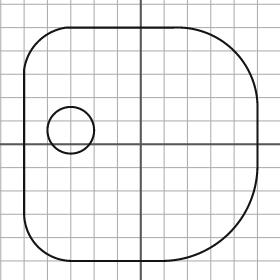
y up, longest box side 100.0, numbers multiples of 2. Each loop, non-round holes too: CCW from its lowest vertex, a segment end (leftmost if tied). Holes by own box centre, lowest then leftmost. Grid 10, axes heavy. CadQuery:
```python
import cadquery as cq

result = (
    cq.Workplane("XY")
    .moveTo(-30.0, -50.0)
    .lineTo(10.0, -50.0)
    .threePointArc((38.0, -38.0), (50.0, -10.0))
    .lineTo(50.0, 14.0)
    .threePointArc((40.0, 40.0), (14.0, 50.0))
    .lineTo(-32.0, 50.0)
    .threePointArc((-44.0, 44.0), (-50.0, 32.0))
    .lineTo(-50.0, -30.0)
    .threePointArc((-44.0, -44.0), (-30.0, -50.0))
    .close()
    .moveTo(-30.0, 6.0)
    .circle(10.0)
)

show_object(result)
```